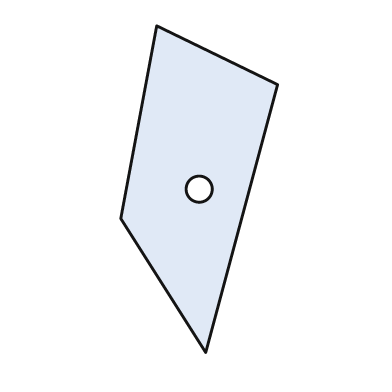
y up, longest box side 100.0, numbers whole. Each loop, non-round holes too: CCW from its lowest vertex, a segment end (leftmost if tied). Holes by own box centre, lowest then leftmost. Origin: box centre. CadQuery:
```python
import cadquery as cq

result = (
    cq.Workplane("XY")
    .moveTo(2.0, -50.0)
    .lineTo(24.0, 32.0)
    .lineTo(-13.0, 50.0)
    .lineTo(-24.0, -9.0)
    .close()
    .moveTo(0.0, 0.0)
    .circle(4.0)
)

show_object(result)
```